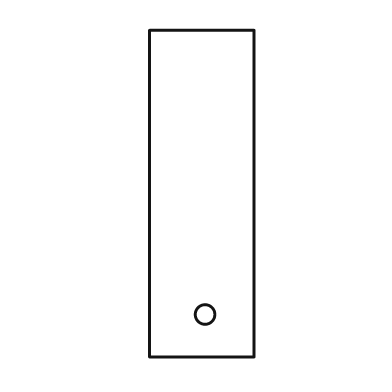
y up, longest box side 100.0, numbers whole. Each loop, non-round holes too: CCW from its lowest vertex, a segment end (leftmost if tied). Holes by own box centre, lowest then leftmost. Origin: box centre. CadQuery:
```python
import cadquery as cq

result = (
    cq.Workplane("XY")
    .moveTo(-16.0, -50.0)
    .lineTo(16.0, -50.0)
    .lineTo(16.0, 50.0)
    .lineTo(-16.0, 50.0)
    .close()
    .moveTo(1.0, -37.0)
    .circle(3.0)
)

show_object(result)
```